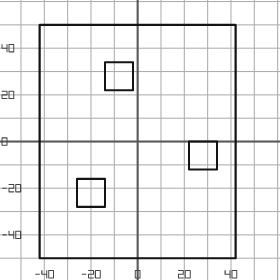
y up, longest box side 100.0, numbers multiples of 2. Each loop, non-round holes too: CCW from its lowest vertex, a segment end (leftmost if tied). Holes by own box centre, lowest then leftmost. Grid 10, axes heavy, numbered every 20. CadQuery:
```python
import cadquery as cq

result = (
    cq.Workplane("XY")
    .moveTo(-42.0, -50.0)
    .lineTo(42.0, -50.0)
    .lineTo(42.0, 50.0)
    .lineTo(-42.0, 50.0)
    .close()
    .moveTo(-26.0, -28.0)
    .lineTo(-14.0, -28.0)
    .lineTo(-14.0, -16.0)
    .lineTo(-26.0, -16.0)
    .close()
    .moveTo(22.0, -12.0)
    .lineTo(34.0, -12.0)
    .lineTo(34.0, 0.0)
    .lineTo(22.0, 0.0)
    .close()
    .moveTo(-14.0, 22.0)
    .lineTo(-2.0, 22.0)
    .lineTo(-2.0, 34.0)
    .lineTo(-14.0, 34.0)
    .close()
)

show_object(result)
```